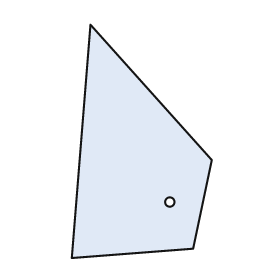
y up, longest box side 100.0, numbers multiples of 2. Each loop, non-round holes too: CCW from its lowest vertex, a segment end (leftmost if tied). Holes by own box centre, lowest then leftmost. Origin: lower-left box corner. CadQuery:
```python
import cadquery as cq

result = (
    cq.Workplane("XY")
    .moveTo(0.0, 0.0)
    .lineTo(52.0, 4.0)
    .lineTo(60.0, 42.0)
    .lineTo(8.0, 100.0)
    .close()
    .moveTo(42.0, 24.0)
    .circle(2.0)
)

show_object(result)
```